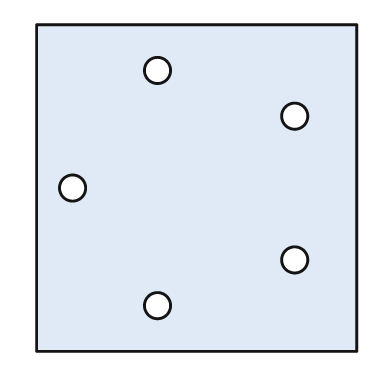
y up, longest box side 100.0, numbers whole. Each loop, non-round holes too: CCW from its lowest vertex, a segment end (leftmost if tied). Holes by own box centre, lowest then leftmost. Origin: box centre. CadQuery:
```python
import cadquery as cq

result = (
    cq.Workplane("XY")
    .moveTo(-49.0, -50.0)
    .lineTo(49.0, -50.0)
    .lineTo(49.0, 50.0)
    .lineTo(-49.0, 50.0)
    .close()
    .moveTo(-12.0, -36.0)
    .circle(4.0)
    .moveTo(30.0, -22.0)
    .circle(4.0)
    .moveTo(-38.0, 0.0)
    .circle(4.0)
    .moveTo(30.0, 22.0)
    .circle(4.0)
    .moveTo(-12.0, 36.0)
    .circle(4.0)
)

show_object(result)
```